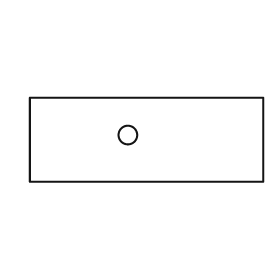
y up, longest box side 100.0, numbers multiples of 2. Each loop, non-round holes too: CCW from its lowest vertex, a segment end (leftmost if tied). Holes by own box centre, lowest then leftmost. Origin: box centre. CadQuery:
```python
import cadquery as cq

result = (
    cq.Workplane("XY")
    .moveTo(-50.0, -18.0)
    .lineTo(50.0, -18.0)
    .lineTo(50.0, 18.0)
    .lineTo(-50.0, 18.0)
    .close()
    .moveTo(-8.0, 2.0)
    .circle(4.0)
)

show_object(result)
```